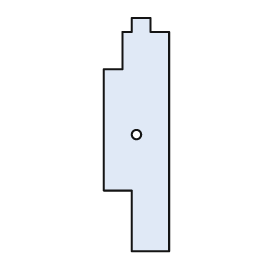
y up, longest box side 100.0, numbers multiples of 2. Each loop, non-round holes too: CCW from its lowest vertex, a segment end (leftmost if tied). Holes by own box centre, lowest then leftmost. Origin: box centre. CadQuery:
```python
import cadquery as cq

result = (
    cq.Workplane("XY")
    .moveTo(-2.0, -50.0)
    .lineTo(14.0, -50.0)
    .lineTo(14.0, 44.0)
    .lineTo(6.0, 44.0)
    .lineTo(6.0, 50.0)
    .lineTo(-2.0, 50.0)
    .lineTo(-2.0, 44.0)
    .lineTo(-6.0, 44.0)
    .lineTo(-6.0, 28.0)
    .lineTo(-14.0, 28.0)
    .lineTo(-14.0, -24.0)
    .lineTo(-2.0, -24.0)
    .close()
    .moveTo(0.0, 0.0)
    .circle(2.0)
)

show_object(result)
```